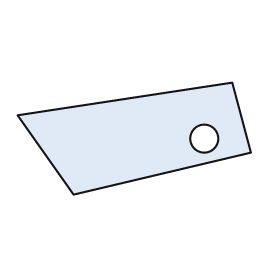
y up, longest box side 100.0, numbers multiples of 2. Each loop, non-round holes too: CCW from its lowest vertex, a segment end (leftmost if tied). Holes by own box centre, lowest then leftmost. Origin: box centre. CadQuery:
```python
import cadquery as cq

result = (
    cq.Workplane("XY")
    .moveTo(-26.0, -24.0)
    .lineTo(50.0, -6.0)
    .lineTo(42.0, 24.0)
    .lineTo(-50.0, 10.0)
    .close()
    .moveTo(30.0, 0.0)
    .circle(6.0)
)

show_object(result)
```